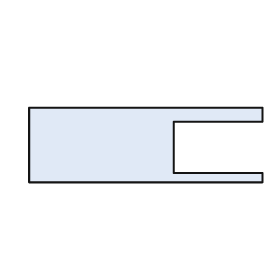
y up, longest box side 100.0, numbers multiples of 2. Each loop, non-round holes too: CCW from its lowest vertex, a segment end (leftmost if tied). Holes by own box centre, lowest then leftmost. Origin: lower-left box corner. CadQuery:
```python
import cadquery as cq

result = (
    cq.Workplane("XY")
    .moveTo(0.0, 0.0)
    .lineTo(100.0, 0.0)
    .lineTo(100.0, 4.0)
    .lineTo(62.0, 4.0)
    .lineTo(62.0, 26.0)
    .lineTo(100.0, 26.0)
    .lineTo(100.0, 32.0)
    .lineTo(0.0, 32.0)
    .close()
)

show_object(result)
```